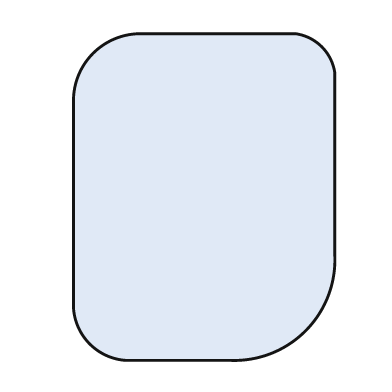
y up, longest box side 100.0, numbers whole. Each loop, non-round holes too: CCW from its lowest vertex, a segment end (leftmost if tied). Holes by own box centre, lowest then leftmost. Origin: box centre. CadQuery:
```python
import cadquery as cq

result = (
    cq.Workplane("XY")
    .moveTo(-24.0, -50.0)
    .lineTo(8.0, -50.0)
    .threePointArc((31.0, -41.0), (40.0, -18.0))
    .lineTo(40.0, 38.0)
    .threePointArc((36.0, 46.0), (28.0, 50.0))
    .lineTo(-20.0, 50.0)
    .threePointArc((-34.0, 44.0), (-40.0, 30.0))
    .lineTo(-40.0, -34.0)
    .threePointArc((-35.0, -45.0), (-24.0, -50.0))
    .close()
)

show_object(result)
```